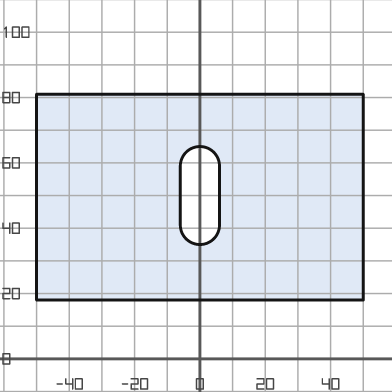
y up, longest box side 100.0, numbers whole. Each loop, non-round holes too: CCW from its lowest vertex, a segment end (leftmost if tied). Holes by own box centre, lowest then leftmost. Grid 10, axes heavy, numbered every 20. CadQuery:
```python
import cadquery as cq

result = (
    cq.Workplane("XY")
    .moveTo(-50.0, 18.0)
    .lineTo(50.0, 18.0)
    .lineTo(50.0, 81.0)
    .lineTo(-50.0, 81.0)
    .close()
    .moveTo(-6.0, 41.0)
    .threePointArc((0.0, 35.0), (6.0, 41.0))
    .lineTo(6.0, 59.0)
    .threePointArc((0.0, 65.0), (-6.0, 59.0))
    .close()
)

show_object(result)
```